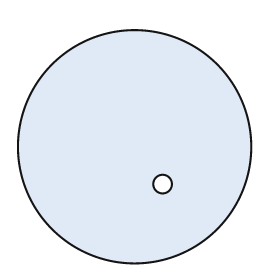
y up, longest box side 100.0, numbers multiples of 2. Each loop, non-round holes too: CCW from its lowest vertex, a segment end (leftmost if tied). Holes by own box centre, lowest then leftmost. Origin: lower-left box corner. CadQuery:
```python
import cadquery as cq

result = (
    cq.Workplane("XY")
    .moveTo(50.0, 50.0)
    .circle(50.0)
    .moveTo(62.0, 34.0)
    .circle(4.0)
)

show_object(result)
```